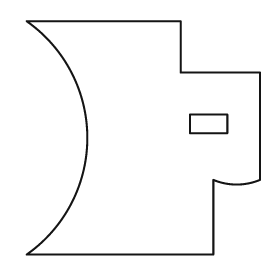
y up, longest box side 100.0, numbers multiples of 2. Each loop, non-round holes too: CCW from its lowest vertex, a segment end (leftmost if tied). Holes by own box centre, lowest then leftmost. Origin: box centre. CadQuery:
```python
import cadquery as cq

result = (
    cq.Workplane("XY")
    .moveTo(-50.0, -50.0)
    .lineTo(30.0, -50.0)
    .lineTo(30.0, -18.0)
    .threePointArc((40.0, -20.0), (50.0, -18.0))
    .lineTo(50.0, 28.0)
    .lineTo(16.0, 28.0)
    .lineTo(16.0, 50.0)
    .lineTo(-50.0, 50.0)
    .threePointArc((-24.0, 0.0), (-50.0, -50.0))
    .close()
    .moveTo(20.0, 2.0)
    .lineTo(36.0, 2.0)
    .lineTo(36.0, 10.0)
    .lineTo(20.0, 10.0)
    .close()
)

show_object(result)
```